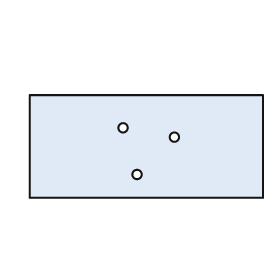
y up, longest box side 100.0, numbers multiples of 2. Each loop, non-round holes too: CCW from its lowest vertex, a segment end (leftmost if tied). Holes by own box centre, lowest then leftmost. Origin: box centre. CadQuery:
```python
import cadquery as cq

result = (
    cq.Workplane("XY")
    .moveTo(-50.0, -22.0)
    .lineTo(50.0, -22.0)
    .lineTo(50.0, 22.0)
    .lineTo(-50.0, 22.0)
    .close()
    .moveTo(-4.0, -12.0)
    .circle(2.0)
    .moveTo(12.0, 4.0)
    .circle(2.0)
    .moveTo(-10.0, 8.0)
    .circle(2.0)
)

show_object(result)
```